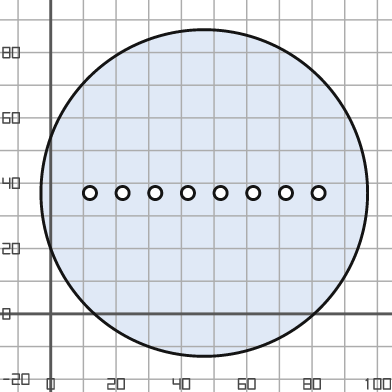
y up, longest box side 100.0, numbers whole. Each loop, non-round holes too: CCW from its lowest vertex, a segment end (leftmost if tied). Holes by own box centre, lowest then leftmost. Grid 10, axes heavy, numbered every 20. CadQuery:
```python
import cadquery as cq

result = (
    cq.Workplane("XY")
    .moveTo(47.0, 37.0)
    .circle(50.0)
    .moveTo(12.0, 37.0)
    .circle(2.0)
    .moveTo(22.0, 37.0)
    .circle(2.0)
    .moveTo(32.0, 37.0)
    .circle(2.0)
    .moveTo(42.0, 37.0)
    .circle(2.0)
    .moveTo(52.0, 37.0)
    .circle(2.0)
    .moveTo(62.0, 37.0)
    .circle(2.0)
    .moveTo(72.0, 37.0)
    .circle(2.0)
    .moveTo(82.0, 37.0)
    .circle(2.0)
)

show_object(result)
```